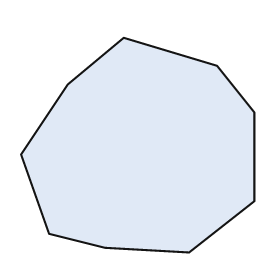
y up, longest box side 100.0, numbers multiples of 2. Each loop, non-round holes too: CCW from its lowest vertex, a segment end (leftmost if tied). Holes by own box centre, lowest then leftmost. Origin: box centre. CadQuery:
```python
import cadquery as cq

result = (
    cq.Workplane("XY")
    .moveTo(22.0, -46.0)
    .lineTo(50.0, -24.0)
    .lineTo(50.0, 14.0)
    .lineTo(34.0, 34.0)
    .lineTo(-6.0, 46.0)
    .lineTo(-30.0, 26.0)
    .lineTo(-50.0, -4.0)
    .lineTo(-38.0, -38.0)
    .lineTo(-14.0, -44.0)
    .close()
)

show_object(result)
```